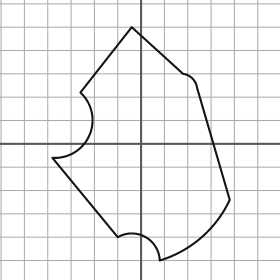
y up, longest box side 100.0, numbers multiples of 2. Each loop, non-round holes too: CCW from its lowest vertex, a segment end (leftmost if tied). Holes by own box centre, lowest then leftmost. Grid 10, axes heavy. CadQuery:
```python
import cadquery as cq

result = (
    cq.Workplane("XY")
    .moveTo(8.0, -50.0)
    .threePointArc((26.0, -40.0), (38.0, -24.0))
    .lineTo(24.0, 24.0)
    .threePointArc((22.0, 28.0), (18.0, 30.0))
    .lineTo(-4.0, 50.0)
    .lineTo(-26.0, 22.0)
    .threePointArc((-22.0, 4.0), (-38.0, -6.0))
    .lineTo(-10.0, -40.0)
    .threePointArc((2.0, -40.0), (8.0, -50.0))
    .close()
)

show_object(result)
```